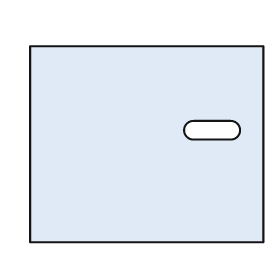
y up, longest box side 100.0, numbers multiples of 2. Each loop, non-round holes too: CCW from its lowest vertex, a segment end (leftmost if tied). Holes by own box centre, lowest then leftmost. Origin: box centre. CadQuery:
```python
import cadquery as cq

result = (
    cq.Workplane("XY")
    .moveTo(-50.0, -42.0)
    .lineTo(50.0, -42.0)
    .lineTo(50.0, 42.0)
    .lineTo(-50.0, 42.0)
    .close()
    .moveTo(20.0, 2.0)
    .lineTo(36.0, 2.0)
    .threePointArc((40.0, 6.0), (36.0, 10.0))
    .lineTo(20.0, 10.0)
    .threePointArc((16.0, 6.0), (20.0, 2.0))
    .close()
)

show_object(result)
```